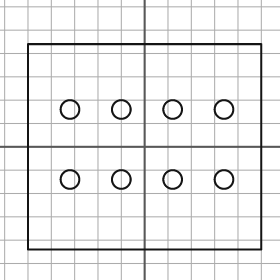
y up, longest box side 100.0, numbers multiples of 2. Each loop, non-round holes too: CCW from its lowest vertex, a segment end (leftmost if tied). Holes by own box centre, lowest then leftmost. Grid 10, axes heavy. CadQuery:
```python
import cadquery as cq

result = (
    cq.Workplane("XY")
    .moveTo(-50.0, -44.0)
    .lineTo(50.0, -44.0)
    .lineTo(50.0, 44.0)
    .lineTo(-50.0, 44.0)
    .close()
    .moveTo(-32.0, -14.0)
    .circle(4.0)
    .moveTo(-10.0, -14.0)
    .circle(4.0)
    .moveTo(12.0, -14.0)
    .circle(4.0)
    .moveTo(34.0, -14.0)
    .circle(4.0)
    .moveTo(-32.0, 16.0)
    .circle(4.0)
    .moveTo(-10.0, 16.0)
    .circle(4.0)
    .moveTo(12.0, 16.0)
    .circle(4.0)
    .moveTo(34.0, 16.0)
    .circle(4.0)
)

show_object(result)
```